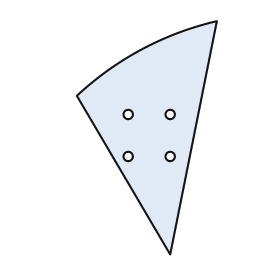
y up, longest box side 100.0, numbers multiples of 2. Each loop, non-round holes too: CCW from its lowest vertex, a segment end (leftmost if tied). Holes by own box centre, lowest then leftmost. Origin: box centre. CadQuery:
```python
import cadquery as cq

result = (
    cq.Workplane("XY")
    .moveTo(10.0, -50.0)
    .lineTo(30.0, 50.0)
    .threePointArc((-2.0, 38.0), (-30.0, 18.0))
    .close()
    .moveTo(-8.0, -8.0)
    .circle(2.0)
    .moveTo(10.0, -8.0)
    .circle(2.0)
    .moveTo(-8.0, 10.0)
    .circle(2.0)
    .moveTo(10.0, 10.0)
    .circle(2.0)
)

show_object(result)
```